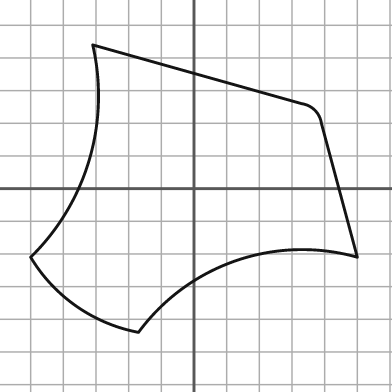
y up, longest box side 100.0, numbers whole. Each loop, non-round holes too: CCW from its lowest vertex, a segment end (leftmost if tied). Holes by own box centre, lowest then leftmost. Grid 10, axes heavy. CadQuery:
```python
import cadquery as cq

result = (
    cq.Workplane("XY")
    .moveTo(-17.0, -44.0)
    .threePointArc((13.0, -22.0), (50.0, -21.0))
    .lineTo(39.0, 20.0)
    .threePointArc((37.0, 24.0), (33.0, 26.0))
    .lineTo(-31.0, 44.0)
    .threePointArc((-32.0, 9.0), (-50.0, -21.0))
    .threePointArc((-36.0, -36.0), (-17.0, -44.0))
    .close()
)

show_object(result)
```